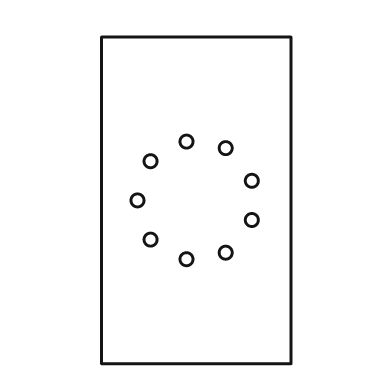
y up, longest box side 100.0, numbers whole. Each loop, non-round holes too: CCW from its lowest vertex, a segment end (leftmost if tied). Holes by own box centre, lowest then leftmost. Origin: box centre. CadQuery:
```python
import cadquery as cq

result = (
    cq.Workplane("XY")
    .moveTo(-29.0, -50.0)
    .lineTo(29.0, -50.0)
    .lineTo(29.0, 50.0)
    .lineTo(-29.0, 50.0)
    .close()
    .moveTo(-3.0, -18.0)
    .circle(2.0)
    .moveTo(9.0, -16.0)
    .circle(2.0)
    .moveTo(-14.0, -12.0)
    .circle(2.0)
    .moveTo(17.0, -6.0)
    .circle(2.0)
    .moveTo(-18.0, 0.0)
    .circle(2.0)
    .moveTo(17.0, 6.0)
    .circle(2.0)
    .moveTo(-14.0, 12.0)
    .circle(2.0)
    .moveTo(9.0, 16.0)
    .circle(2.0)
    .moveTo(-3.0, 18.0)
    .circle(2.0)
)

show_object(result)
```